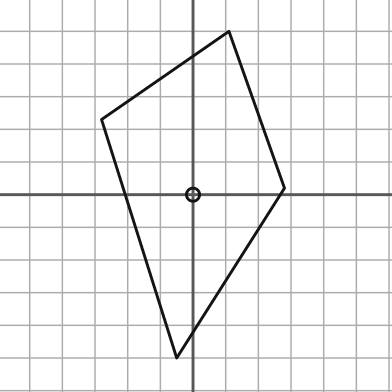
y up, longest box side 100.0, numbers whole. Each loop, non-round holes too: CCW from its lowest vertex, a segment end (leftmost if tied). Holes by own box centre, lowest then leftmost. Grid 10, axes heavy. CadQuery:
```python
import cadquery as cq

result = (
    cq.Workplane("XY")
    .moveTo(-5.0, -50.0)
    .lineTo(28.0, 2.0)
    .lineTo(11.0, 50.0)
    .lineTo(-28.0, 23.0)
    .close()
    .moveTo(0.0, 0.0)
    .circle(2.0)
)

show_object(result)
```